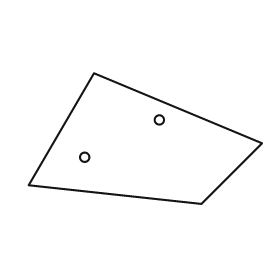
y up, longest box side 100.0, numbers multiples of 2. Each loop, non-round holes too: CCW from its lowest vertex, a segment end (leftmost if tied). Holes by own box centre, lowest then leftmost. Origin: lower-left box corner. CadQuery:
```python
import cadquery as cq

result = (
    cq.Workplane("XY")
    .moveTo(74.0, 0.0)
    .lineTo(100.0, 26.0)
    .lineTo(28.0, 56.0)
    .lineTo(0.0, 8.0)
    .close()
    .moveTo(24.0, 20.0)
    .circle(2.0)
    .moveTo(56.0, 36.0)
    .circle(2.0)
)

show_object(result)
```